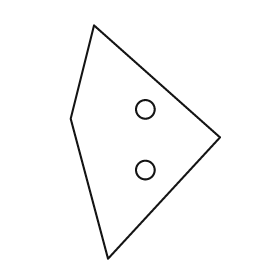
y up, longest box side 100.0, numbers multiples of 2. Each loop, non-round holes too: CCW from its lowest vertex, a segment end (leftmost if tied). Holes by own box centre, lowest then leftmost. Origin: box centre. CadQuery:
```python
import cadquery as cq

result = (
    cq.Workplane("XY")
    .moveTo(-16.0, -50.0)
    .lineTo(32.0, 2.0)
    .lineTo(-22.0, 50.0)
    .lineTo(-32.0, 10.0)
    .close()
    .moveTo(0.0, -12.0)
    .circle(4.0)
    .moveTo(0.0, 14.0)
    .circle(4.0)
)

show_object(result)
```